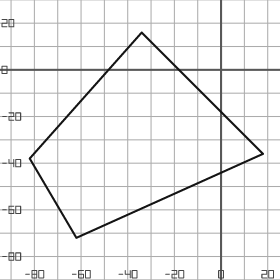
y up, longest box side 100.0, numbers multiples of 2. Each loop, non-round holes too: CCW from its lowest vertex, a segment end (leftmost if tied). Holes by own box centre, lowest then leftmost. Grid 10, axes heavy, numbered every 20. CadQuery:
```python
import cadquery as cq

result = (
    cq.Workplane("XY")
    .moveTo(-62.0, -72.0)
    .lineTo(18.0, -36.0)
    .lineTo(-34.0, 16.0)
    .lineTo(-82.0, -38.0)
    .close()
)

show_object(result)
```